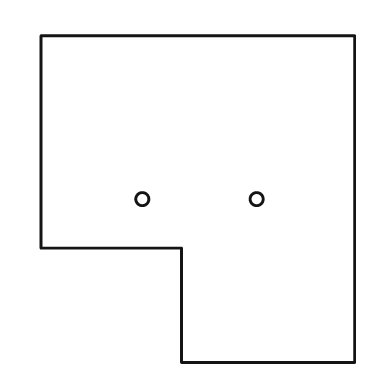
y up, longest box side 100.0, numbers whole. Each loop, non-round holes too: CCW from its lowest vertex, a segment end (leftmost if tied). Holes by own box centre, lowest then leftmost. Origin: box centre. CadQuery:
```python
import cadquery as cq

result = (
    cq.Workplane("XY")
    .moveTo(-5.0, -50.0)
    .lineTo(48.0, -50.0)
    .lineTo(48.0, 50.0)
    .lineTo(-48.0, 50.0)
    .lineTo(-48.0, -15.0)
    .lineTo(-5.0, -15.0)
    .close()
    .moveTo(-17.0, 0.0)
    .circle(2.0)
    .moveTo(18.0, 0.0)
    .circle(2.0)
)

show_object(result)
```